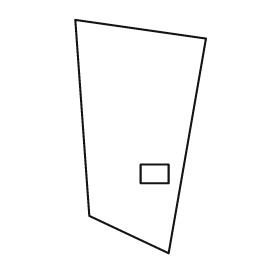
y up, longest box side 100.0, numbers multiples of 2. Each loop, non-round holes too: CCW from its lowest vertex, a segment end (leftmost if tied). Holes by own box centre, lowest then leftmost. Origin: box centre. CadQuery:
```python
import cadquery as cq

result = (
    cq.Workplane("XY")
    .moveTo(12.0, -50.0)
    .lineTo(28.0, 42.0)
    .lineTo(-28.0, 50.0)
    .lineTo(-22.0, -34.0)
    .close()
    .moveTo(0.0, -20.0)
    .lineTo(12.0, -20.0)
    .lineTo(12.0, -12.0)
    .lineTo(0.0, -12.0)
    .close()
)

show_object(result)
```